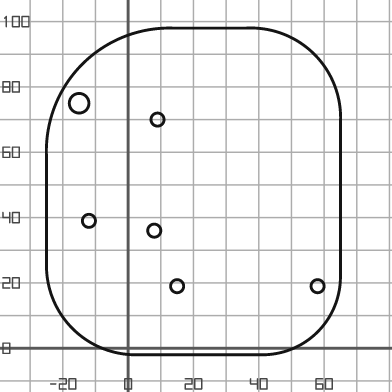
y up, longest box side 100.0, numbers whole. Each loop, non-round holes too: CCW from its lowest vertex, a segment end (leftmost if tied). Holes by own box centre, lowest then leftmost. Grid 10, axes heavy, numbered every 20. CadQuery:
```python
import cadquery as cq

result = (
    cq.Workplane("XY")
    .moveTo(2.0, -2.0)
    .lineTo(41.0, -2.0)
    .threePointArc((58.0, 5.0), (65.0, 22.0))
    .lineTo(65.0, 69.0)
    .threePointArc((57.0, 90.0), (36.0, 98.0))
    .lineTo(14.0, 98.0)
    .threePointArc((-14.0, 87.0), (-25.0, 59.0))
    .lineTo(-25.0, 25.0)
    .threePointArc((-17.0, 6.0), (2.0, -2.0))
    .close()
    .moveTo(15.0, 19.0)
    .circle(2.0)
    .moveTo(58.0, 19.0)
    .circle(2.0)
    .moveTo(8.0, 36.0)
    .circle(2.0)
    .moveTo(-12.0, 39.0)
    .circle(2.0)
    .moveTo(9.0, 70.0)
    .circle(2.0)
    .moveTo(-15.0, 75.0)
    .circle(3.0)
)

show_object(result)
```